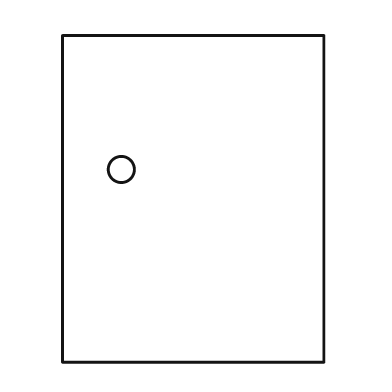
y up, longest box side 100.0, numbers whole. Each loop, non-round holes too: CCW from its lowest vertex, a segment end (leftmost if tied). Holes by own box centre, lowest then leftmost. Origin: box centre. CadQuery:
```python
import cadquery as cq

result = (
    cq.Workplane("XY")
    .moveTo(-40.0, -50.0)
    .lineTo(40.0, -50.0)
    .lineTo(40.0, 50.0)
    .lineTo(-40.0, 50.0)
    .close()
    .moveTo(-22.0, 9.0)
    .circle(4.0)
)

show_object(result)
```